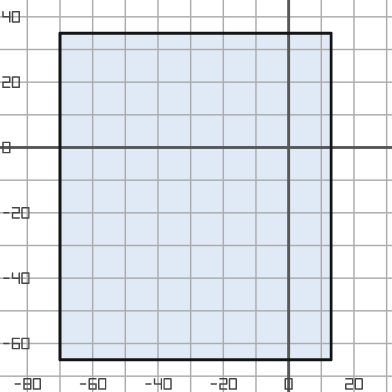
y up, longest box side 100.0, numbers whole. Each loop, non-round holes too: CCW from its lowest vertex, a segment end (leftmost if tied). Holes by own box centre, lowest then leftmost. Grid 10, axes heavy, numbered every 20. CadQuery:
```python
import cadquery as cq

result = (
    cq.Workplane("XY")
    .moveTo(-70.0, -65.0)
    .lineTo(13.0, -65.0)
    .lineTo(13.0, 35.0)
    .lineTo(-70.0, 35.0)
    .close()
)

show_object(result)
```